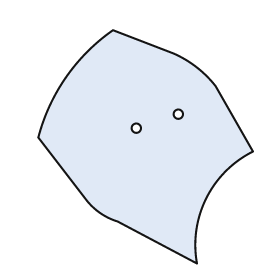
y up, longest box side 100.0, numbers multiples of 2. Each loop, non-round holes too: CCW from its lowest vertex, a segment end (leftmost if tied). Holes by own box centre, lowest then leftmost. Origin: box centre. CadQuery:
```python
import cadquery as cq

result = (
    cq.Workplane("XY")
    .moveTo(22.0, -50.0)
    .threePointArc((26.0, -22.0), (46.0, -2.0))
    .lineTo(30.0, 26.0)
    .threePointArc((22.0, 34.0), (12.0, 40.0))
    .lineTo(-14.0, 50.0)
    .threePointArc((-34.0, 30.0), (-46.0, 4.0))
    .lineTo(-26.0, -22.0)
    .threePointArc((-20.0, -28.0), (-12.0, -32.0))
    .close()
    .moveTo(-4.0, 8.0)
    .circle(2.0)
    .moveTo(14.0, 14.0)
    .circle(2.0)
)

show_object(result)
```